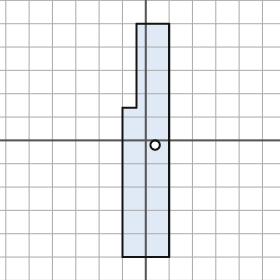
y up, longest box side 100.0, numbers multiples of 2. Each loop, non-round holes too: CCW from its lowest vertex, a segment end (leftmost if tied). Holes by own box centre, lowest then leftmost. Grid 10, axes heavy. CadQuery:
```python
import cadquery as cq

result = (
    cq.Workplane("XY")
    .moveTo(-10.0, -50.0)
    .lineTo(10.0, -50.0)
    .lineTo(10.0, 50.0)
    .lineTo(-4.0, 50.0)
    .lineTo(-4.0, 14.0)
    .lineTo(-10.0, 14.0)
    .close()
    .moveTo(4.0, -2.0)
    .circle(2.0)
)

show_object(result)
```